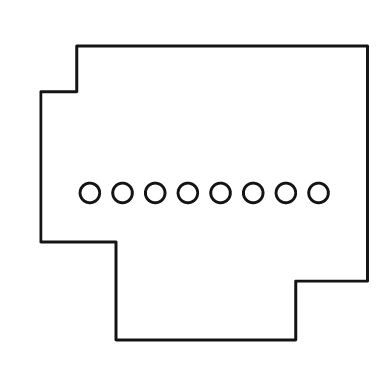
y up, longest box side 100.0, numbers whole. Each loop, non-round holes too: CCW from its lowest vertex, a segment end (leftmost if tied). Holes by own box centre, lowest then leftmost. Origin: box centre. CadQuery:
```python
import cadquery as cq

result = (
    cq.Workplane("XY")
    .moveTo(-27.0, -45.0)
    .lineTo(28.0, -45.0)
    .lineTo(28.0, -27.0)
    .lineTo(50.0, -27.0)
    .lineTo(50.0, 45.0)
    .lineTo(-39.0, 45.0)
    .lineTo(-39.0, 31.0)
    .lineTo(-50.0, 31.0)
    .lineTo(-50.0, -15.0)
    .lineTo(-27.0, -15.0)
    .close()
    .moveTo(-35.0, 0.0)
    .circle(3.0)
    .moveTo(-25.0, 0.0)
    .circle(3.0)
    .moveTo(-15.0, 0.0)
    .circle(3.0)
    .moveTo(-5.0, 0.0)
    .circle(3.0)
    .moveTo(5.0, 0.0)
    .circle(3.0)
    .moveTo(15.0, 0.0)
    .circle(3.0)
    .moveTo(25.0, 0.0)
    .circle(3.0)
    .moveTo(35.0, 0.0)
    .circle(3.0)
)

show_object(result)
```